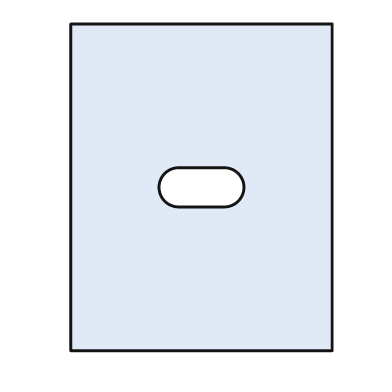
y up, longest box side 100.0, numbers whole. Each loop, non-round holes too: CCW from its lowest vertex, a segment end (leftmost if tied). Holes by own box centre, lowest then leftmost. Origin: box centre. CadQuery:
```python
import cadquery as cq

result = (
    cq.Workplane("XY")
    .moveTo(-40.0, -50.0)
    .lineTo(40.0, -50.0)
    .lineTo(40.0, 50.0)
    .lineTo(-40.0, 50.0)
    .close()
    .moveTo(-7.0, -6.0)
    .lineTo(7.0, -6.0)
    .threePointArc((13.0, 0.0), (7.0, 6.0))
    .lineTo(-7.0, 6.0)
    .threePointArc((-13.0, 0.0), (-7.0, -6.0))
    .close()
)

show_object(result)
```